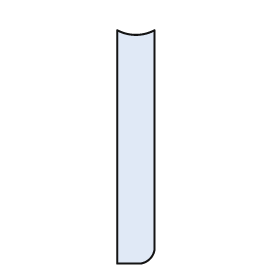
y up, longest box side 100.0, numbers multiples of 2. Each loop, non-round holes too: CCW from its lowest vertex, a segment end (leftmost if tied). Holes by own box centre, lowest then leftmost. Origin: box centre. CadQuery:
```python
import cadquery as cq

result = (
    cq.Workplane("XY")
    .moveTo(-8.0, -50.0)
    .lineTo(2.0, -50.0)
    .threePointArc((6.0, -48.0), (8.0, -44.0))
    .lineTo(8.0, 50.0)
    .threePointArc((0.0, 48.0), (-8.0, 50.0))
    .close()
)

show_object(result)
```